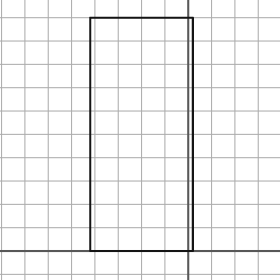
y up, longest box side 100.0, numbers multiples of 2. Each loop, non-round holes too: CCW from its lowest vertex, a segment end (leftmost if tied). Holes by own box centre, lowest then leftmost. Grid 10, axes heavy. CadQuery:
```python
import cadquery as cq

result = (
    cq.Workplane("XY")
    .moveTo(-42.0, 0.0)
    .lineTo(2.0, 0.0)
    .lineTo(2.0, 100.0)
    .lineTo(-42.0, 100.0)
    .close()
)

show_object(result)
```